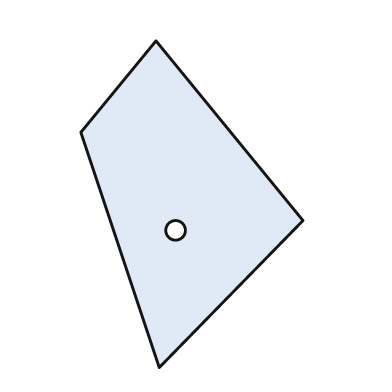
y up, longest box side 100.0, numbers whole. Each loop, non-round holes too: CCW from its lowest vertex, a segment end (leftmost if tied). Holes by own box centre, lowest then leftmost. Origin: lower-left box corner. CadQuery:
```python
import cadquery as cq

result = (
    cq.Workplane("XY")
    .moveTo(24.0, 0.0)
    .lineTo(68.0, 45.0)
    .lineTo(23.0, 100.0)
    .lineTo(0.0, 72.0)
    .close()
    .moveTo(29.0, 42.0)
    .circle(3.0)
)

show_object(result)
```